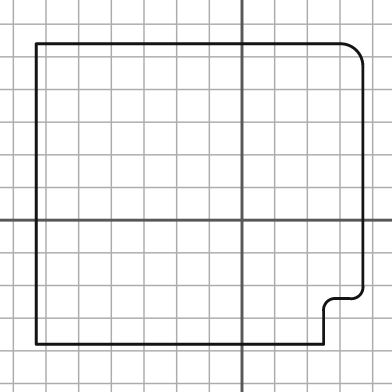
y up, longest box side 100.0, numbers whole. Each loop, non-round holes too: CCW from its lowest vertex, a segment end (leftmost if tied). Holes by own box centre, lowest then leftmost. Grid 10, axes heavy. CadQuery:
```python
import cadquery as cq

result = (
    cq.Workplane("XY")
    .moveTo(-63.0, -38.0)
    .lineTo(25.0, -38.0)
    .lineTo(25.0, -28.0)
    .threePointArc((26.0, -25.0), (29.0, -24.0))
    .lineTo(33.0, -24.0)
    .threePointArc((36.0, -23.0), (37.0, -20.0))
    .lineTo(37.0, 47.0)
    .threePointArc((35.0, 52.0), (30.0, 54.0))
    .lineTo(-63.0, 54.0)
    .close()
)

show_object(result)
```